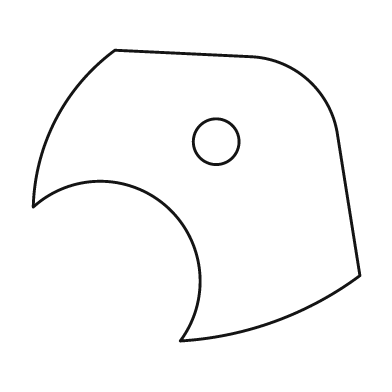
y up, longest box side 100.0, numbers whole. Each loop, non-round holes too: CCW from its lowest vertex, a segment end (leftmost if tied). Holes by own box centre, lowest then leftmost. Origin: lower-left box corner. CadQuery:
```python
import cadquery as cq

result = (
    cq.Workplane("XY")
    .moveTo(45.0, 0.0)
    .threePointArc((74.0, 6.0), (100.0, 20.0))
    .lineTo(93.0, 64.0)
    .threePointArc((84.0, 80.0), (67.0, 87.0))
    .lineTo(25.0, 89.0)
    .threePointArc((7.0, 68.0), (0.0, 41.0))
    .threePointArc((41.0, 41.0), (45.0, 0.0))
    .close()
    .moveTo(56.0, 61.0)
    .circle(7.0)
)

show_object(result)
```